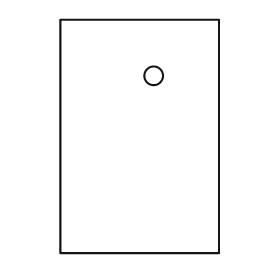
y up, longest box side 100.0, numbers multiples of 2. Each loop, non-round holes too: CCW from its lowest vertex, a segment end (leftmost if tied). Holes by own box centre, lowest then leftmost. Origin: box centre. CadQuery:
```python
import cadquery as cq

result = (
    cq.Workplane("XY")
    .moveTo(-34.0, -50.0)
    .lineTo(34.0, -50.0)
    .lineTo(34.0, 50.0)
    .lineTo(-34.0, 50.0)
    .close()
    .moveTo(6.0, 26.0)
    .circle(4.0)
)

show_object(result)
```